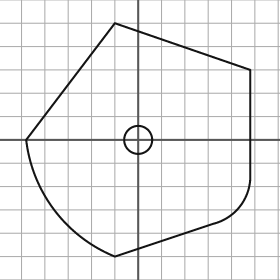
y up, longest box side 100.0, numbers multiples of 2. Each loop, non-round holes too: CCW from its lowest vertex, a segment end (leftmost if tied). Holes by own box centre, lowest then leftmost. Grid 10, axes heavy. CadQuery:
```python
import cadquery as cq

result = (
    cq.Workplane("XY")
    .moveTo(-10.0, -50.0)
    .lineTo(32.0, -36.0)
    .threePointArc((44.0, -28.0), (48.0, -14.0))
    .lineTo(48.0, 30.0)
    .lineTo(-10.0, 50.0)
    .lineTo(-48.0, 0.0)
    .threePointArc((-36.0, -30.0), (-10.0, -50.0))
    .close()
    .moveTo(0.0, 0.0)
    .circle(6.0)
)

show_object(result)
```